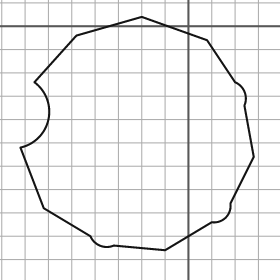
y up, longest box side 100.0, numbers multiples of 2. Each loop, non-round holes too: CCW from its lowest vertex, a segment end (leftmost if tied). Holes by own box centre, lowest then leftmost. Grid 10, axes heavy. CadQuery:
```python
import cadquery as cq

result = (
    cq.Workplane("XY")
    .moveTo(-10.0, -96.0)
    .lineTo(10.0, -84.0)
    .threePointArc((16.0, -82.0), (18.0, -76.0))
    .lineTo(28.0, -56.0)
    .lineTo(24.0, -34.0)
    .threePointArc((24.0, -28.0), (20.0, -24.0))
    .lineTo(8.0, -6.0)
    .lineTo(-20.0, 4.0)
    .lineTo(-48.0, -4.0)
    .lineTo(-66.0, -24.0)
    .threePointArc((-60.0, -40.0), (-72.0, -52.0))
    .lineTo(-62.0, -78.0)
    .lineTo(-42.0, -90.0)
    .threePointArc((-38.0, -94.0), (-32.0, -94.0))
    .close()
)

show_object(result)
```